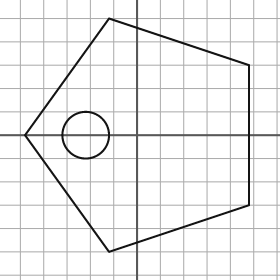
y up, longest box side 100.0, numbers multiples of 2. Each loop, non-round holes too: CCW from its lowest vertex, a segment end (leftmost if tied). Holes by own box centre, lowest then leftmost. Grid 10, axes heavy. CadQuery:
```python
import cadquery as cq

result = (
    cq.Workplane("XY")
    .moveTo(-12.0, -50.0)
    .lineTo(48.0, -30.0)
    .lineTo(48.0, 30.0)
    .lineTo(-12.0, 50.0)
    .lineTo(-48.0, 0.0)
    .close()
    .moveTo(-22.0, 0.0)
    .circle(10.0)
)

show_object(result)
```